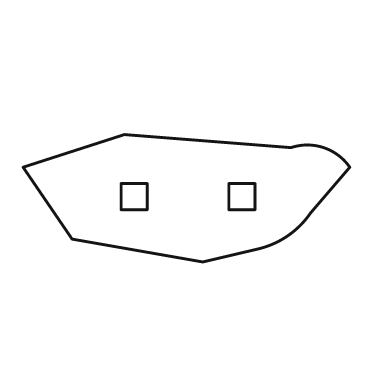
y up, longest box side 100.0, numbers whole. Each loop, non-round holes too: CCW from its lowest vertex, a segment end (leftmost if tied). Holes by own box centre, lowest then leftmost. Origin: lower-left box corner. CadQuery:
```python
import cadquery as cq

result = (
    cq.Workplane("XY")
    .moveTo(55.0, 0.0)
    .lineTo(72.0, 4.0)
    .threePointArc((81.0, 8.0), (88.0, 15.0))
    .lineTo(100.0, 29.0)
    .threePointArc((92.0, 35.0), (82.0, 35.0))
    .lineTo(31.0, 39.0)
    .lineTo(0.0, 29.0)
    .lineTo(15.0, 7.0)
    .close()
    .moveTo(30.0, 16.0)
    .lineTo(38.0, 16.0)
    .lineTo(38.0, 24.0)
    .lineTo(30.0, 24.0)
    .close()
    .moveTo(63.0, 16.0)
    .lineTo(71.0, 16.0)
    .lineTo(71.0, 24.0)
    .lineTo(63.0, 24.0)
    .close()
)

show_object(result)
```